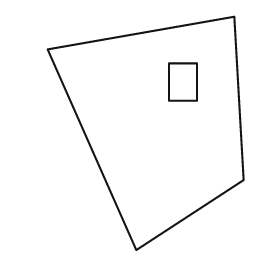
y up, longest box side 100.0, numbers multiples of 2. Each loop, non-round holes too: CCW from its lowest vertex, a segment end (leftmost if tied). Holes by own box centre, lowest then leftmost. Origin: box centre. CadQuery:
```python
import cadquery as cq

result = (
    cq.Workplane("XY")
    .moveTo(-4.0, -50.0)
    .lineTo(42.0, -20.0)
    .lineTo(38.0, 50.0)
    .lineTo(-42.0, 36.0)
    .close()
    .moveTo(10.0, 14.0)
    .lineTo(22.0, 14.0)
    .lineTo(22.0, 30.0)
    .lineTo(10.0, 30.0)
    .close()
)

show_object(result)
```